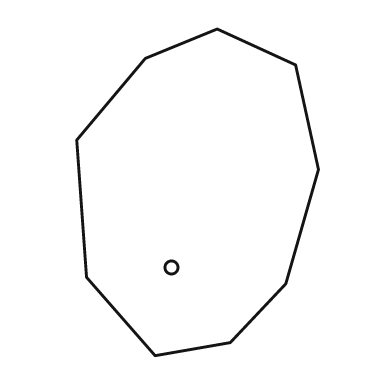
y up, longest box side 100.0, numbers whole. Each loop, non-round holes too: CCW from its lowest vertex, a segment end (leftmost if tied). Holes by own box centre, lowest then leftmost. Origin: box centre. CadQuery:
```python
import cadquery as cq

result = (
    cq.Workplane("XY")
    .moveTo(-13.0, -50.0)
    .lineTo(10.0, -46.0)
    .lineTo(27.0, -28.0)
    .lineTo(37.0, 7.0)
    .lineTo(30.0, 39.0)
    .lineTo(6.0, 50.0)
    .lineTo(-16.0, 41.0)
    .lineTo(-37.0, 16.0)
    .lineTo(-34.0, -26.0)
    .close()
    .moveTo(-8.0, -23.0)
    .circle(2.0)
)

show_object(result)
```